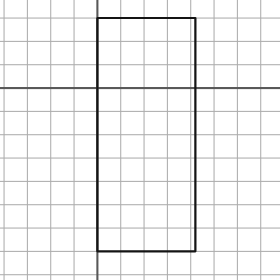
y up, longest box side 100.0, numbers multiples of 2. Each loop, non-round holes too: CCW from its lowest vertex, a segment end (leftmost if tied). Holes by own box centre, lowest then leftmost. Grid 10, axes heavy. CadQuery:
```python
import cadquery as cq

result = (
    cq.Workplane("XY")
    .moveTo(0.0, -70.0)
    .lineTo(42.0, -70.0)
    .lineTo(42.0, 30.0)
    .lineTo(0.0, 30.0)
    .close()
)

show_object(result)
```